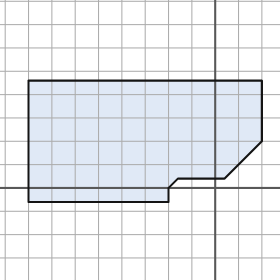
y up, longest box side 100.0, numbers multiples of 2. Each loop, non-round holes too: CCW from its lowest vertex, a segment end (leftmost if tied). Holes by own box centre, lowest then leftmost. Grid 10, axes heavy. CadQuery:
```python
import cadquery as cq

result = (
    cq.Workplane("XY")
    .moveTo(-80.0, -6.0)
    .lineTo(-20.0, -6.0)
    .lineTo(-20.0, 0.0)
    .lineTo(-16.0, 4.0)
    .lineTo(4.0, 4.0)
    .lineTo(20.0, 20.0)
    .lineTo(20.0, 46.0)
    .lineTo(-80.0, 46.0)
    .close()
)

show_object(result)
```